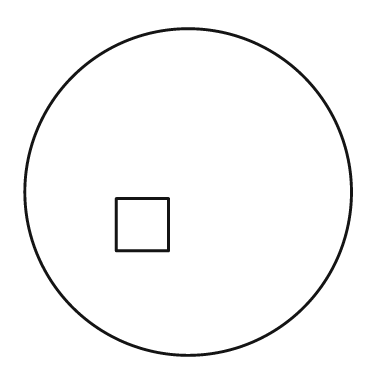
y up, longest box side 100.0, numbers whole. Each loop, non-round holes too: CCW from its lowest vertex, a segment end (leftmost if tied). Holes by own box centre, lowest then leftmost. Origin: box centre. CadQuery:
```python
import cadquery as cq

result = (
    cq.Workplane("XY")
    .moveTo(0.0, 0.0)
    .circle(50.0)
    .moveTo(-22.0, -18.0)
    .lineTo(-6.0, -18.0)
    .lineTo(-6.0, -2.0)
    .lineTo(-22.0, -2.0)
    .close()
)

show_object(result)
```